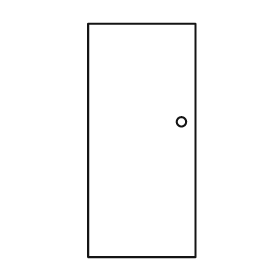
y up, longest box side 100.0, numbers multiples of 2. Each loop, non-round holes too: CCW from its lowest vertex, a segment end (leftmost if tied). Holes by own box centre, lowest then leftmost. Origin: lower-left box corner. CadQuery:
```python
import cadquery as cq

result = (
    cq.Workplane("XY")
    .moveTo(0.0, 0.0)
    .lineTo(46.0, 0.0)
    .lineTo(46.0, 100.0)
    .lineTo(0.0, 100.0)
    .close()
    .moveTo(40.0, 58.0)
    .circle(2.0)
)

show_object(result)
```